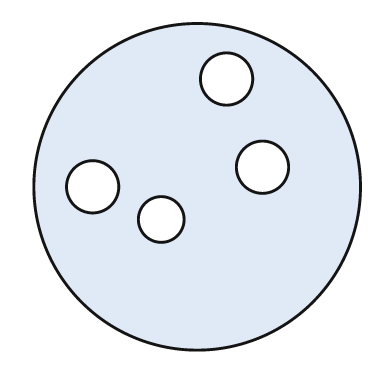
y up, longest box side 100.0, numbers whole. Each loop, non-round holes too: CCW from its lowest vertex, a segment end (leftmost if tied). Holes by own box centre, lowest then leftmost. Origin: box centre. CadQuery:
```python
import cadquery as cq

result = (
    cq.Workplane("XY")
    .moveTo(0.0, 0.0)
    .circle(50.0)
    .moveTo(-11.0, -10.0)
    .circle(7.0)
    .moveTo(-32.0, 0.0)
    .circle(8.0)
    .moveTo(20.0, 6.0)
    .circle(8.0)
    .moveTo(9.0, 33.0)
    .circle(8.0)
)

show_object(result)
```